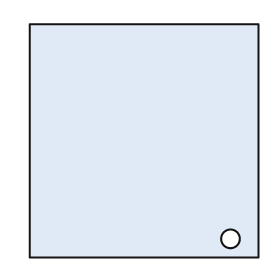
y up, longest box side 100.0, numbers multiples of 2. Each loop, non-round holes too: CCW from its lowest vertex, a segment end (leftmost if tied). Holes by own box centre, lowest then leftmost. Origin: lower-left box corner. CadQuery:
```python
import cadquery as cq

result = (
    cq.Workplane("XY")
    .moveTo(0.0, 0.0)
    .lineTo(98.0, 0.0)
    .lineTo(98.0, 100.0)
    .lineTo(0.0, 100.0)
    .close()
    .moveTo(86.0, 8.0)
    .circle(4.0)
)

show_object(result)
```